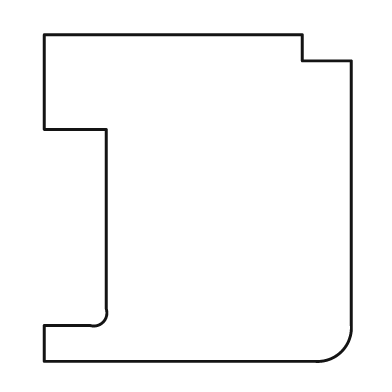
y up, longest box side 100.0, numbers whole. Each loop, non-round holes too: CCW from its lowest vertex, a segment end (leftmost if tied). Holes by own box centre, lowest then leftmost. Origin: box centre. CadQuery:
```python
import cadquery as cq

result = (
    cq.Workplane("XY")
    .moveTo(-47.0, -50.0)
    .lineTo(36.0, -50.0)
    .threePointArc((44.0, -47.0), (47.0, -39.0))
    .lineTo(47.0, 42.0)
    .lineTo(32.0, 42.0)
    .lineTo(32.0, 50.0)
    .lineTo(-47.0, 50.0)
    .lineTo(-47.0, 21.0)
    .lineTo(-28.0, 21.0)
    .lineTo(-28.0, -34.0)
    .threePointArc((-29.0, -38.0), (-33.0, -39.0))
    .lineTo(-47.0, -39.0)
    .close()
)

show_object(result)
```